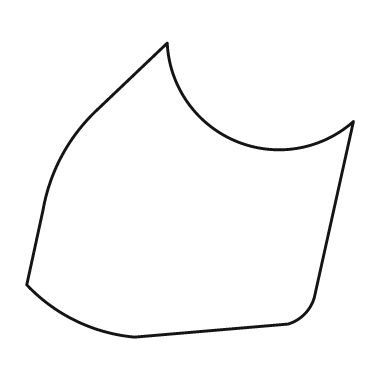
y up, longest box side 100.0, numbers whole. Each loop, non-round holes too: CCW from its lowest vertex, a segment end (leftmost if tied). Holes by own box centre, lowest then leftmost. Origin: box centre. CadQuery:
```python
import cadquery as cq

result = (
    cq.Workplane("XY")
    .moveTo(-17.0, -45.0)
    .lineTo(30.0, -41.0)
    .threePointArc((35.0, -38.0), (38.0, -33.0))
    .lineTo(50.0, 21.0)
    .threePointArc((14.0, 15.0), (-7.0, 45.0))
    .lineTo(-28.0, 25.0)
    .threePointArc((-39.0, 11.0), (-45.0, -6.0))
    .lineTo(-50.0, -29.0)
    .threePointArc((-35.0, -40.0), (-17.0, -45.0))
    .close()
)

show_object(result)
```